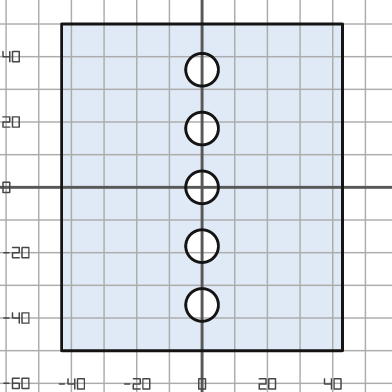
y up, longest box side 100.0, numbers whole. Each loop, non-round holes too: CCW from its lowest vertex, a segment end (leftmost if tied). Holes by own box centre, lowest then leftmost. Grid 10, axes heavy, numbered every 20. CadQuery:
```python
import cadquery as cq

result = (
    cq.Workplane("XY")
    .moveTo(-43.0, -50.0)
    .lineTo(43.0, -50.0)
    .lineTo(43.0, 50.0)
    .lineTo(-43.0, 50.0)
    .close()
    .moveTo(0.0, -36.0)
    .circle(5.0)
    .moveTo(0.0, -18.0)
    .circle(5.0)
    .moveTo(0.0, 0.0)
    .circle(5.0)
    .moveTo(0.0, 18.0)
    .circle(5.0)
    .moveTo(0.0, 36.0)
    .circle(5.0)
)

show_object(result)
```